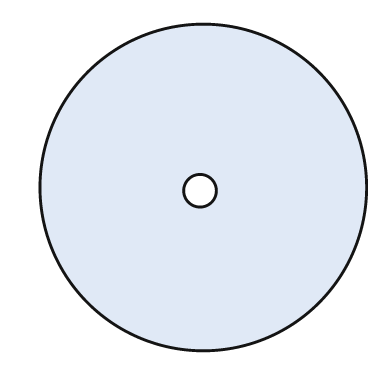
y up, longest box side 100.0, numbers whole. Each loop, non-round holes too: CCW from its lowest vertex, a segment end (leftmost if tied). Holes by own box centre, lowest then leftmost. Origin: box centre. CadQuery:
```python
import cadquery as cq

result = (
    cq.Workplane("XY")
    .moveTo(0.0, 0.0)
    .circle(50.0)
    .moveTo(-1.0, -1.0)
    .circle(5.0)
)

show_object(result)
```